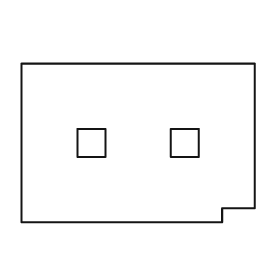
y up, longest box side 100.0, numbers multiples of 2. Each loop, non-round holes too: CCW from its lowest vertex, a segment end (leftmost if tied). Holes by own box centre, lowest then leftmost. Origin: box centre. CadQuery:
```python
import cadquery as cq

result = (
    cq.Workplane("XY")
    .moveTo(-50.0, -34.0)
    .lineTo(36.0, -34.0)
    .lineTo(36.0, -28.0)
    .lineTo(50.0, -28.0)
    .lineTo(50.0, 34.0)
    .lineTo(-50.0, 34.0)
    .close()
    .moveTo(-26.0, -6.0)
    .lineTo(-14.0, -6.0)
    .lineTo(-14.0, 6.0)
    .lineTo(-26.0, 6.0)
    .close()
    .moveTo(14.0, -6.0)
    .lineTo(26.0, -6.0)
    .lineTo(26.0, 6.0)
    .lineTo(14.0, 6.0)
    .close()
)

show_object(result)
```